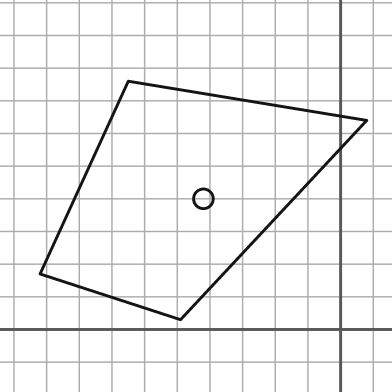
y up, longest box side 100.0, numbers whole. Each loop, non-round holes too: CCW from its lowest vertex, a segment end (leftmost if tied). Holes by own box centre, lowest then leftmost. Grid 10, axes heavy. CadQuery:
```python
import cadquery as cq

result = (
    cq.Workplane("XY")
    .moveTo(-49.0, 3.0)
    .lineTo(8.0, 64.0)
    .lineTo(-65.0, 76.0)
    .lineTo(-92.0, 17.0)
    .close()
    .moveTo(-42.0, 40.0)
    .circle(3.0)
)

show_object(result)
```